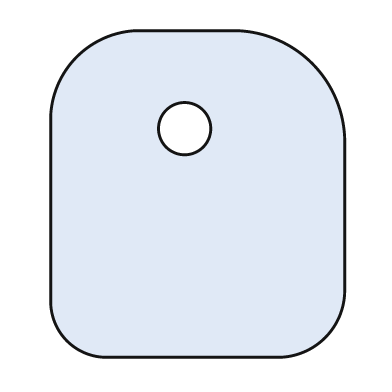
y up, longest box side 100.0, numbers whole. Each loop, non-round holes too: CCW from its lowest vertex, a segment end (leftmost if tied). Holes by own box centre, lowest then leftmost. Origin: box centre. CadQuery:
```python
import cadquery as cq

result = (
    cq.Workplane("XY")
    .moveTo(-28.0, -50.0)
    .lineTo(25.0, -50.0)
    .threePointArc((39.0, -44.0), (45.0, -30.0))
    .lineTo(45.0, 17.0)
    .threePointArc((35.0, 40.0), (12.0, 50.0))
    .lineTo(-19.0, 50.0)
    .threePointArc((-37.0, 42.0), (-45.0, 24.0))
    .lineTo(-45.0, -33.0)
    .threePointArc((-40.0, -45.0), (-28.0, -50.0))
    .close()
    .moveTo(-4.0, 20.0)
    .circle(8.0)
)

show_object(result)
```